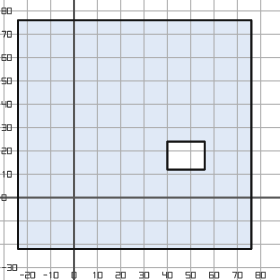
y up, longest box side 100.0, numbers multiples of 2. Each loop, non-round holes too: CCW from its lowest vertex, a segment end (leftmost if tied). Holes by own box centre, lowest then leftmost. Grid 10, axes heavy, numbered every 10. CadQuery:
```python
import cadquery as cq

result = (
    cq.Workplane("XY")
    .moveTo(-24.0, -22.0)
    .lineTo(76.0, -22.0)
    .lineTo(76.0, 76.0)
    .lineTo(-24.0, 76.0)
    .close()
    .moveTo(40.0, 12.0)
    .lineTo(56.0, 12.0)
    .lineTo(56.0, 24.0)
    .lineTo(40.0, 24.0)
    .close()
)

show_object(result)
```